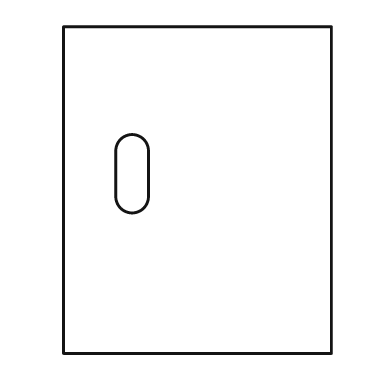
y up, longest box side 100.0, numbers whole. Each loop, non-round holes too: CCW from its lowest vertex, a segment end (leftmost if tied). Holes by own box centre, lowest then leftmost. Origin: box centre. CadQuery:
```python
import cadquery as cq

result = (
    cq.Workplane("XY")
    .moveTo(-41.0, -50.0)
    .lineTo(41.0, -50.0)
    .lineTo(41.0, 50.0)
    .lineTo(-41.0, 50.0)
    .close()
    .moveTo(-25.0, -2.0)
    .threePointArc((-20.0, -7.0), (-15.0, -2.0))
    .lineTo(-15.0, 12.0)
    .threePointArc((-20.0, 17.0), (-25.0, 12.0))
    .close()
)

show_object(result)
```